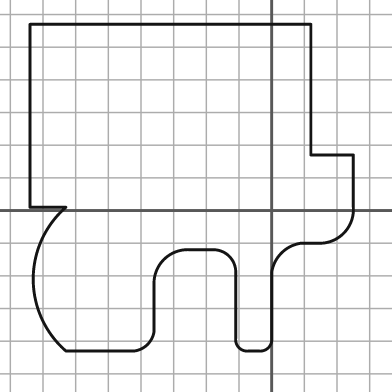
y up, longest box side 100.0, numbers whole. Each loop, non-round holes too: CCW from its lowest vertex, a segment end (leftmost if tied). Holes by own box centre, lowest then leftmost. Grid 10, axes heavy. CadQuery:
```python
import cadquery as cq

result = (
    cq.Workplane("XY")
    .moveTo(-63.0, -43.0)
    .lineTo(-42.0, -43.0)
    .threePointArc((-38.0, -41.0), (-36.0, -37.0))
    .lineTo(-36.0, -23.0)
    .threePointArc((-33.0, -15.0), (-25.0, -12.0))
    .lineTo(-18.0, -12.0)
    .threePointArc((-13.0, -14.0), (-11.0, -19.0))
    .lineTo(-11.0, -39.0)
    .threePointArc((-10.0, -42.0), (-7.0, -43.0))
    .lineTo(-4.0, -43.0)
    .threePointArc((-1.0, -42.0), (0.0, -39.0))
    .lineTo(0.0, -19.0)
    .threePointArc((3.0, -13.0), (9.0, -10.0))
    .lineTo(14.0, -10.0)
    .threePointArc((22.0, -7.0), (25.0, 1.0))
    .lineTo(25.0, 17.0)
    .lineTo(12.0, 17.0)
    .lineTo(12.0, 57.0)
    .lineTo(-74.0, 57.0)
    .lineTo(-74.0, 1.0)
    .lineTo(-63.0, 1.0)
    .threePointArc((-73.0, -21.0), (-63.0, -43.0))
    .close()
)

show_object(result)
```